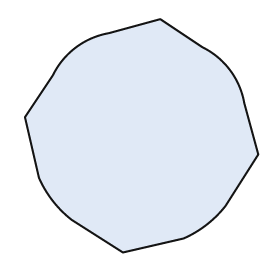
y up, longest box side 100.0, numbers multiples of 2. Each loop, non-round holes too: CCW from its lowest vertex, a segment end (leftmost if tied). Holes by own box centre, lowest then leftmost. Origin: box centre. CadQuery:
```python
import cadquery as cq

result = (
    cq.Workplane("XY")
    .moveTo(-8.0, -50.0)
    .lineTo(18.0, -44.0)
    .threePointArc((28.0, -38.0), (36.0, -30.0))
    .lineTo(50.0, -8.0)
    .lineTo(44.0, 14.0)
    .threePointArc((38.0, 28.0), (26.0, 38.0))
    .lineTo(8.0, 50.0)
    .lineTo(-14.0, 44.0)
    .threePointArc((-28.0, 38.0), (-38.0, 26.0))
    .lineTo(-50.0, 8.0)
    .lineTo(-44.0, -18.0)
    .threePointArc((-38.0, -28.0), (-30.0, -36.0))
    .close()
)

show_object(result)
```